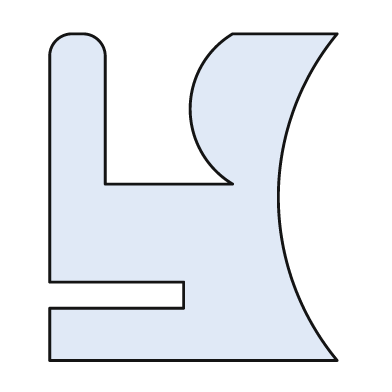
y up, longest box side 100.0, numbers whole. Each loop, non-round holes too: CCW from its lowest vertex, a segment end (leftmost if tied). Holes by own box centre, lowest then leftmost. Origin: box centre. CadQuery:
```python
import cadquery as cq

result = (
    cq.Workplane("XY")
    .moveTo(-44.0, -50.0)
    .lineTo(44.0, -50.0)
    .threePointArc((26.0, 0.0), (44.0, 50.0))
    .lineTo(12.0, 50.0)
    .threePointArc((-1.0, 27.0), (12.0, 4.0))
    .lineTo(-27.0, 4.0)
    .lineTo(-27.0, 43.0)
    .threePointArc((-29.0, 48.0), (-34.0, 50.0))
    .lineTo(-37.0, 50.0)
    .threePointArc((-42.0, 48.0), (-44.0, 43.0))
    .lineTo(-44.0, -26.0)
    .lineTo(-3.0, -26.0)
    .lineTo(-3.0, -34.0)
    .lineTo(-44.0, -34.0)
    .close()
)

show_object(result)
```